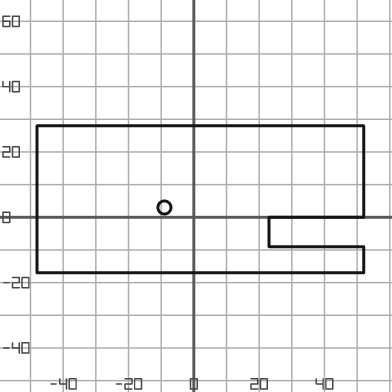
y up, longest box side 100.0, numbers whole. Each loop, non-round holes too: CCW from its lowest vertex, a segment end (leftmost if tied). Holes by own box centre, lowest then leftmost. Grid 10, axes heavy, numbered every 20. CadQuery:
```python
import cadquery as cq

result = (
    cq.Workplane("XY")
    .moveTo(-48.0, -17.0)
    .lineTo(52.0, -17.0)
    .lineTo(52.0, -9.0)
    .lineTo(23.0, -9.0)
    .lineTo(23.0, 0.0)
    .lineTo(52.0, 0.0)
    .lineTo(52.0, 28.0)
    .lineTo(-48.0, 28.0)
    .close()
    .moveTo(-9.0, 3.0)
    .circle(2.0)
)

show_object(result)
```